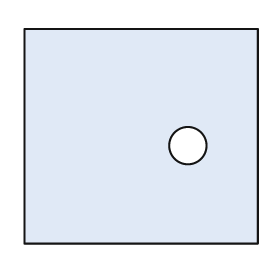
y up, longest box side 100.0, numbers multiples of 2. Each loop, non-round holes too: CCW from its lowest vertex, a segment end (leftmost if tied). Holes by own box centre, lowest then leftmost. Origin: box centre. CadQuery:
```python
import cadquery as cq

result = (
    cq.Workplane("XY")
    .moveTo(-50.0, -46.0)
    .lineTo(50.0, -46.0)
    .lineTo(50.0, 46.0)
    .lineTo(-50.0, 46.0)
    .close()
    .moveTo(20.0, -4.0)
    .circle(8.0)
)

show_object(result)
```